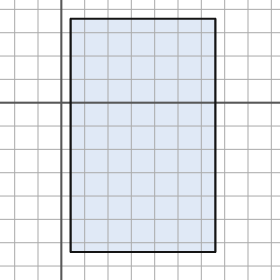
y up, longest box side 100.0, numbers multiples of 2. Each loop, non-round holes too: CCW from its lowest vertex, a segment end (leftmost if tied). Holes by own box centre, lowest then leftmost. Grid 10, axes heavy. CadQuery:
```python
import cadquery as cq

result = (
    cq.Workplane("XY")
    .moveTo(4.0, -64.0)
    .lineTo(66.0, -64.0)
    .lineTo(66.0, 36.0)
    .lineTo(4.0, 36.0)
    .close()
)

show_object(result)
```